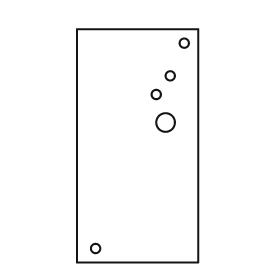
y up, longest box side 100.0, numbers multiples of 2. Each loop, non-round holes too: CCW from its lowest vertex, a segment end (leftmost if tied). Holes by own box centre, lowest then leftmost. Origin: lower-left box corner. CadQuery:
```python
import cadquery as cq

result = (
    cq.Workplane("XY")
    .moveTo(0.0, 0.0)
    .lineTo(52.0, 0.0)
    .lineTo(52.0, 100.0)
    .lineTo(0.0, 100.0)
    .close()
    .moveTo(8.0, 6.0)
    .circle(2.0)
    .moveTo(38.0, 60.0)
    .circle(4.0)
    .moveTo(34.0, 72.0)
    .circle(2.0)
    .moveTo(40.0, 80.0)
    .circle(2.0)
    .moveTo(46.0, 94.0)
    .circle(2.0)
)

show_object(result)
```